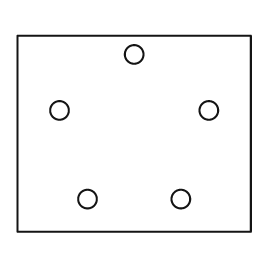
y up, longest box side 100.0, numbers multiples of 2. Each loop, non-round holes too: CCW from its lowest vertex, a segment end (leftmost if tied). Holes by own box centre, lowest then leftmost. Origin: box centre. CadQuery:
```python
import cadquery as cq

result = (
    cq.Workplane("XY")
    .moveTo(-50.0, -42.0)
    .lineTo(50.0, -42.0)
    .lineTo(50.0, 42.0)
    .lineTo(-50.0, 42.0)
    .close()
    .moveTo(-20.0, -28.0)
    .circle(4.0)
    .moveTo(20.0, -28.0)
    .circle(4.0)
    .moveTo(-32.0, 10.0)
    .circle(4.0)
    .moveTo(32.0, 10.0)
    .circle(4.0)
    .moveTo(0.0, 34.0)
    .circle(4.0)
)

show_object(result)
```